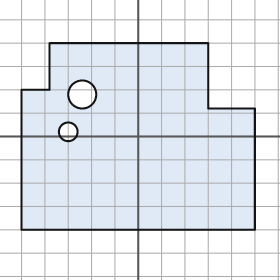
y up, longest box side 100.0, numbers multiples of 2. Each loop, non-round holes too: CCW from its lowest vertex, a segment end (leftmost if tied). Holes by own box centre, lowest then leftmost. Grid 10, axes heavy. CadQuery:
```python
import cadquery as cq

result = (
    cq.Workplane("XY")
    .moveTo(-50.0, -40.0)
    .lineTo(50.0, -40.0)
    .lineTo(50.0, 12.0)
    .lineTo(30.0, 12.0)
    .lineTo(30.0, 40.0)
    .lineTo(-38.0, 40.0)
    .lineTo(-38.0, 20.0)
    .lineTo(-50.0, 20.0)
    .close()
    .moveTo(-30.0, 2.0)
    .circle(4.0)
    .moveTo(-24.0, 18.0)
    .circle(6.0)
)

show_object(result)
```